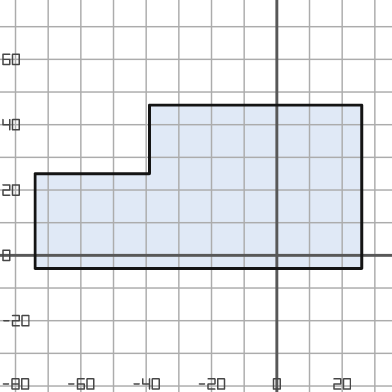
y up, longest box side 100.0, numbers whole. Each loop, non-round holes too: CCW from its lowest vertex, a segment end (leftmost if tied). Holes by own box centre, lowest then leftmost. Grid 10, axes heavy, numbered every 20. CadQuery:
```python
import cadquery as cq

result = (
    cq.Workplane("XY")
    .moveTo(-74.0, -4.0)
    .lineTo(26.0, -4.0)
    .lineTo(26.0, 46.0)
    .lineTo(-39.0, 46.0)
    .lineTo(-39.0, 25.0)
    .lineTo(-74.0, 25.0)
    .close()
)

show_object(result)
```